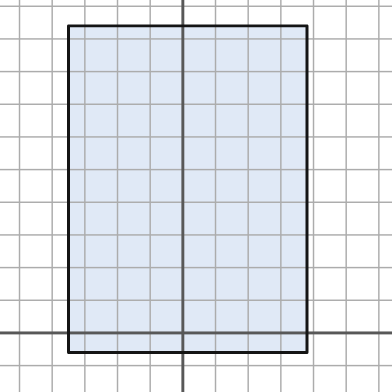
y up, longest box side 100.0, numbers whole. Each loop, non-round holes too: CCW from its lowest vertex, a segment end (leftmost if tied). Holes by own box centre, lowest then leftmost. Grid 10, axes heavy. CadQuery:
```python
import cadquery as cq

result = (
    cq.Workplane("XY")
    .moveTo(-35.0, -6.0)
    .lineTo(38.0, -6.0)
    .lineTo(38.0, 94.0)
    .lineTo(-35.0, 94.0)
    .close()
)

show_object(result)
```